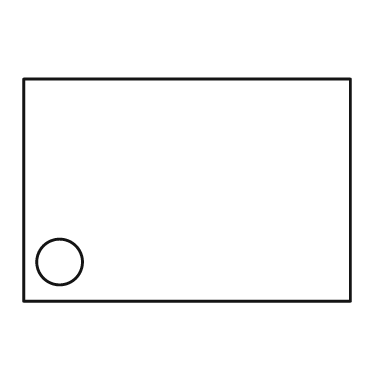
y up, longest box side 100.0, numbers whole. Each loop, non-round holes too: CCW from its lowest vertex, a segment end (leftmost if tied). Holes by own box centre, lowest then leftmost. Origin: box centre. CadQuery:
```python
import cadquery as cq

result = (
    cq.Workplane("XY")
    .moveTo(-50.0, -34.0)
    .lineTo(50.0, -34.0)
    .lineTo(50.0, 34.0)
    .lineTo(-50.0, 34.0)
    .close()
    .moveTo(-39.0, -22.0)
    .circle(7.0)
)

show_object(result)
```